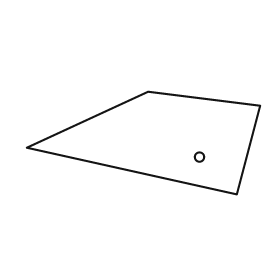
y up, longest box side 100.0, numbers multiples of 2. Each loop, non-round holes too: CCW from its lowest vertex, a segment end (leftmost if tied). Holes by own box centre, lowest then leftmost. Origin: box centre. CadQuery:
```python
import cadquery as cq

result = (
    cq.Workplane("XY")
    .moveTo(40.0, -22.0)
    .lineTo(50.0, 16.0)
    .lineTo(2.0, 22.0)
    .lineTo(-50.0, -2.0)
    .close()
    .moveTo(24.0, -6.0)
    .circle(2.0)
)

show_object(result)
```